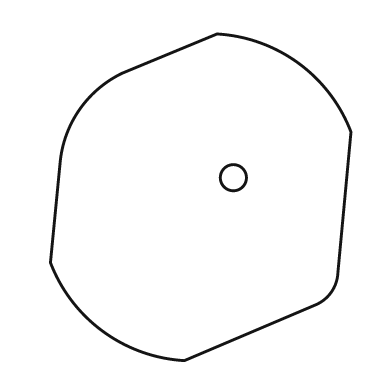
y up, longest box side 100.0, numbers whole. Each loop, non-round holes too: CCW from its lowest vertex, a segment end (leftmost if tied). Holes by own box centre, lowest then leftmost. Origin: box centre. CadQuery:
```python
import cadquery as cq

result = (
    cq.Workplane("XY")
    .moveTo(-5.0, -50.0)
    .lineTo(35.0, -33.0)
    .threePointArc((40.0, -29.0), (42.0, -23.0))
    .lineTo(46.0, 20.0)
    .threePointArc((30.0, 41.0), (5.0, 50.0))
    .lineTo(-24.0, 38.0)
    .threePointArc((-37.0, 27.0), (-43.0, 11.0))
    .lineTo(-46.0, -20.0)
    .threePointArc((-30.0, -41.0), (-5.0, -50.0))
    .close()
    .moveTo(10.0, 6.0)
    .circle(4.0)
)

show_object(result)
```